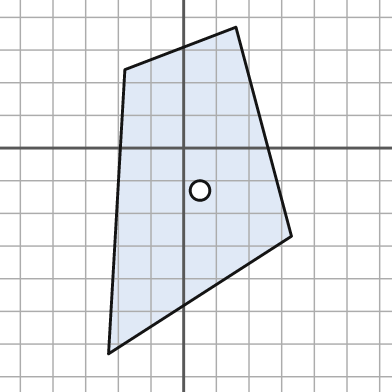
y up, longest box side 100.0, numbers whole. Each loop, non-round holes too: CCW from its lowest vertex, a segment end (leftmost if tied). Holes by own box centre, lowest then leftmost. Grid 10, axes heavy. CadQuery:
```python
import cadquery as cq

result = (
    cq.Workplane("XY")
    .moveTo(-23.0, -63.0)
    .lineTo(33.0, -27.0)
    .lineTo(16.0, 37.0)
    .lineTo(-18.0, 24.0)
    .close()
    .moveTo(5.0, -13.0)
    .circle(3.0)
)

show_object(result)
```